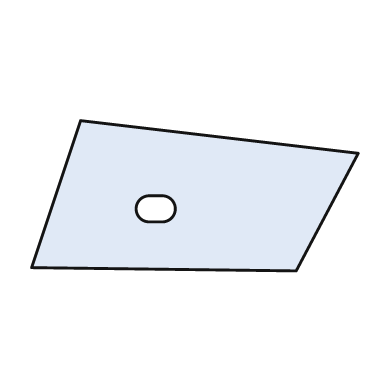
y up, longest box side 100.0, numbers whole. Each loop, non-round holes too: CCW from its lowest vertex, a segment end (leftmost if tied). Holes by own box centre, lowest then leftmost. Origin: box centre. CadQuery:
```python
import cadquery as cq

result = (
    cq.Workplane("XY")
    .moveTo(31.0, -23.0)
    .lineTo(50.0, 13.0)
    .lineTo(-35.0, 23.0)
    .lineTo(-50.0, -22.0)
    .close()
    .moveTo(-14.0, -8.0)
    .lineTo(-10.0, -8.0)
    .threePointArc((-6.0, -4.0), (-10.0, 0.0))
    .lineTo(-14.0, 0.0)
    .threePointArc((-18.0, -4.0), (-14.0, -8.0))
    .close()
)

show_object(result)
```